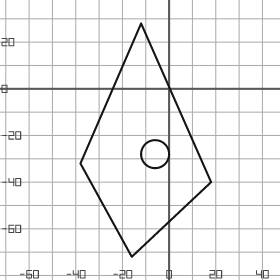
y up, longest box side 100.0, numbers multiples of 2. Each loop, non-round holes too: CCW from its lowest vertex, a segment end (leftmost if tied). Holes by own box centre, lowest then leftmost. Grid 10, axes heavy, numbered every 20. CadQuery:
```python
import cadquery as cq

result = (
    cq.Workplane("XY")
    .moveTo(-16.0, -72.0)
    .lineTo(18.0, -40.0)
    .lineTo(-12.0, 28.0)
    .lineTo(-38.0, -32.0)
    .close()
    .moveTo(-6.0, -28.0)
    .circle(6.0)
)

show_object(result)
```